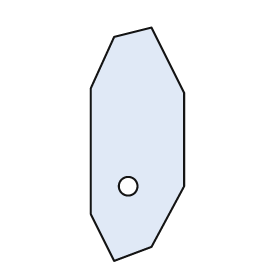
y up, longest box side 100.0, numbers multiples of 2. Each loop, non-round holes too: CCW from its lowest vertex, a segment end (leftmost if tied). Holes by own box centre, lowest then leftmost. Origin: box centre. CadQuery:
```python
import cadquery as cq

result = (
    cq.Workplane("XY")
    .moveTo(-10.0, -50.0)
    .lineTo(6.0, -44.0)
    .lineTo(20.0, -18.0)
    .lineTo(20.0, 22.0)
    .lineTo(6.0, 50.0)
    .lineTo(-10.0, 46.0)
    .lineTo(-20.0, 24.0)
    .lineTo(-20.0, -30.0)
    .close()
    .moveTo(-4.0, -18.0)
    .circle(4.0)
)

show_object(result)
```